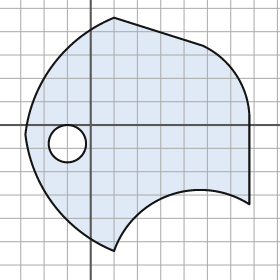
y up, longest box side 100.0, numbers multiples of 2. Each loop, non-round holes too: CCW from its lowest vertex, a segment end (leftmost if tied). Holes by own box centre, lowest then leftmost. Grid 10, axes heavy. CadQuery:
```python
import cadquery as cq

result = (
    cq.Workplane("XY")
    .moveTo(10.0, -54.0)
    .threePointArc((34.0, -30.0), (68.0, -34.0))
    .lineTo(68.0, 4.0)
    .threePointArc((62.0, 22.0), (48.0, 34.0))
    .lineTo(10.0, 46.0)
    .threePointArc((-16.0, 26.0), (-28.0, -4.0))
    .threePointArc((-16.0, -34.0), (10.0, -54.0))
    .close()
    .moveTo(-10.0, -8.0)
    .circle(8.0)
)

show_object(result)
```